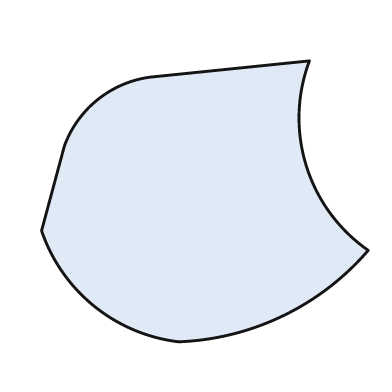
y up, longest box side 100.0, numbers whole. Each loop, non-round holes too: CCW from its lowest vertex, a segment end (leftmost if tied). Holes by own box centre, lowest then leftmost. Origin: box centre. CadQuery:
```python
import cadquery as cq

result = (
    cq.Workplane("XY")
    .moveTo(-8.0, -43.0)
    .threePointArc((24.0, -35.0), (50.0, -15.0))
    .threePointArc((31.0, 11.0), (32.0, 43.0))
    .lineTo(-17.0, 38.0)
    .threePointArc((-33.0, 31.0), (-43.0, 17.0))
    .lineTo(-50.0, -9.0)
    .threePointArc((-34.0, -32.0), (-8.0, -43.0))
    .close()
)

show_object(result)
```